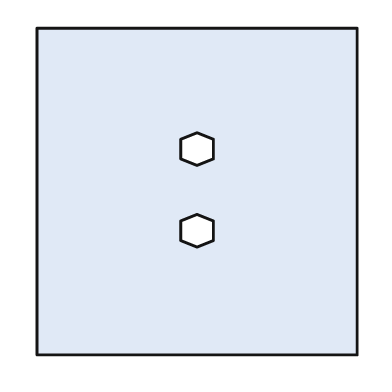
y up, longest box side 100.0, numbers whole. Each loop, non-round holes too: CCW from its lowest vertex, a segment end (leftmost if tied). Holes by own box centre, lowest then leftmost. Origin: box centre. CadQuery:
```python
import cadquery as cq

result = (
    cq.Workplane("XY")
    .moveTo(-49.0, -50.0)
    .lineTo(49.0, -50.0)
    .lineTo(49.0, 50.0)
    .lineTo(-49.0, 50.0)
    .close()
    .moveTo(0.0, -17.0)
    .lineTo(5.0, -15.0)
    .lineTo(5.0, -9.0)
    .lineTo(0.0, -7.0)
    .lineTo(-5.0, -9.0)
    .lineTo(-5.0, -15.0)
    .close()
    .moveTo(0.0, 8.0)
    .lineTo(5.0, 10.0)
    .lineTo(5.0, 16.0)
    .lineTo(0.0, 18.0)
    .lineTo(-5.0, 16.0)
    .lineTo(-5.0, 10.0)
    .close()
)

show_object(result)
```